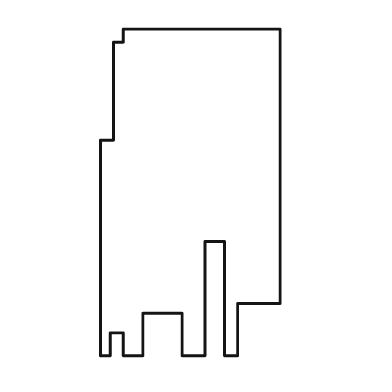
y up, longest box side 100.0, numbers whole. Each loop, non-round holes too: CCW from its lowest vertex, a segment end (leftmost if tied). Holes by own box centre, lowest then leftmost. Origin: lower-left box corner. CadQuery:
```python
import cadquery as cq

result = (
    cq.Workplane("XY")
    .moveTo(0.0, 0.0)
    .lineTo(3.0, 0.0)
    .lineTo(3.0, 7.0)
    .lineTo(7.0, 7.0)
    .lineTo(7.0, 0.0)
    .lineTo(13.0, 0.0)
    .lineTo(13.0, 13.0)
    .lineTo(25.0, 13.0)
    .lineTo(25.0, 0.0)
    .lineTo(32.0, 0.0)
    .lineTo(32.0, 35.0)
    .lineTo(38.0, 35.0)
    .lineTo(38.0, 0.0)
    .lineTo(42.0, 0.0)
    .lineTo(42.0, 16.0)
    .lineTo(55.0, 16.0)
    .lineTo(55.0, 100.0)
    .lineTo(7.0, 100.0)
    .lineTo(7.0, 96.0)
    .lineTo(4.0, 96.0)
    .lineTo(4.0, 66.0)
    .lineTo(0.0, 66.0)
    .close()
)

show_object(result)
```